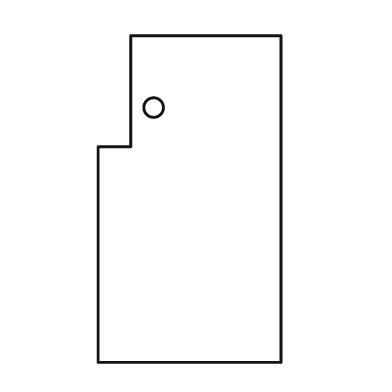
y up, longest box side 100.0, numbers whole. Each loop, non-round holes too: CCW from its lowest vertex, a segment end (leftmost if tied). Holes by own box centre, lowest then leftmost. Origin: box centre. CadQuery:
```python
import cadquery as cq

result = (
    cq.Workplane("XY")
    .moveTo(-28.0, -50.0)
    .lineTo(28.0, -50.0)
    .lineTo(28.0, 50.0)
    .lineTo(-18.0, 50.0)
    .lineTo(-18.0, 16.0)
    .lineTo(-28.0, 16.0)
    .close()
    .moveTo(-11.0, 28.0)
    .circle(3.0)
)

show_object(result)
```